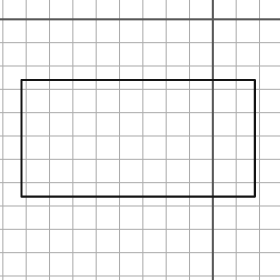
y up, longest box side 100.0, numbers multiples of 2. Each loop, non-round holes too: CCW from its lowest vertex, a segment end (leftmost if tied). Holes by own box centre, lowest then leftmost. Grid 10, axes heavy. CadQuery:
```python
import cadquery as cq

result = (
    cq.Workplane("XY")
    .moveTo(-82.0, -76.0)
    .lineTo(18.0, -76.0)
    .lineTo(18.0, -26.0)
    .lineTo(-82.0, -26.0)
    .close()
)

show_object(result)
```